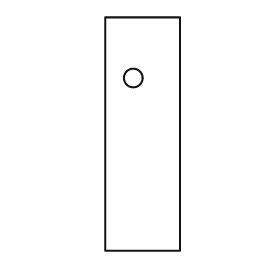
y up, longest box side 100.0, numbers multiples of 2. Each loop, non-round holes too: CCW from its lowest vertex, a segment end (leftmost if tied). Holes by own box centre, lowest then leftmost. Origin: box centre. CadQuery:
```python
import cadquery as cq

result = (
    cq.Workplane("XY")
    .moveTo(-16.0, -50.0)
    .lineTo(16.0, -50.0)
    .lineTo(16.0, 50.0)
    .lineTo(-16.0, 50.0)
    .close()
    .moveTo(-4.0, 24.0)
    .circle(4.0)
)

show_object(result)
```